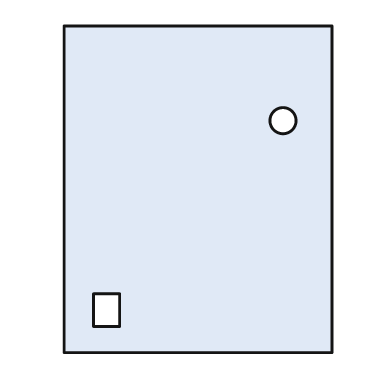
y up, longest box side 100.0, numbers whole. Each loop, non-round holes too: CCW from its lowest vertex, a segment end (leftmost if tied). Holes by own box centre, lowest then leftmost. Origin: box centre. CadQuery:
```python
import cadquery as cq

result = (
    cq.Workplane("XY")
    .moveTo(-41.0, -50.0)
    .lineTo(41.0, -50.0)
    .lineTo(41.0, 50.0)
    .lineTo(-41.0, 50.0)
    .close()
    .moveTo(-32.0, -42.0)
    .lineTo(-24.0, -42.0)
    .lineTo(-24.0, -32.0)
    .lineTo(-32.0, -32.0)
    .close()
    .moveTo(26.0, 21.0)
    .circle(4.0)
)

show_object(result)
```